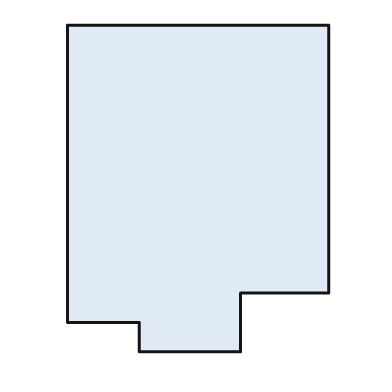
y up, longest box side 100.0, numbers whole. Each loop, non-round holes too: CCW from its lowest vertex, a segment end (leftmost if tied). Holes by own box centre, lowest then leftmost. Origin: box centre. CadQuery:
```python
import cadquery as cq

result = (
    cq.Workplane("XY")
    .moveTo(-18.0, -50.0)
    .lineTo(13.0, -50.0)
    .lineTo(13.0, -32.0)
    .lineTo(40.0, -32.0)
    .lineTo(40.0, 50.0)
    .lineTo(-40.0, 50.0)
    .lineTo(-40.0, -41.0)
    .lineTo(-18.0, -41.0)
    .close()
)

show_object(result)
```